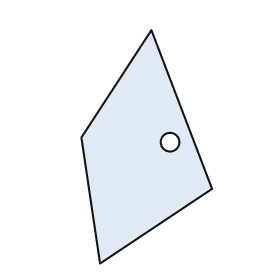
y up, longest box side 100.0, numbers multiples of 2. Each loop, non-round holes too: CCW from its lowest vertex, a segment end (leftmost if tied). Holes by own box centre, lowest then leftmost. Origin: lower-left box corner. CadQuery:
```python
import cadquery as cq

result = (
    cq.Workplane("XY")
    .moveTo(8.0, 0.0)
    .lineTo(56.0, 32.0)
    .lineTo(30.0, 100.0)
    .lineTo(0.0, 54.0)
    .close()
    .moveTo(38.0, 52.0)
    .circle(4.0)
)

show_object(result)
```